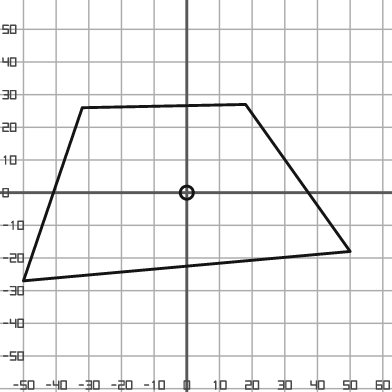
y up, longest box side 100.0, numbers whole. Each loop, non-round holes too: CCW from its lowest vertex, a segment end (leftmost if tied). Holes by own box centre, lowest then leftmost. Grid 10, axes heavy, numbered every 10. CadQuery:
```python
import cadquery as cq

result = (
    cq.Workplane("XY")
    .moveTo(-50.0, -27.0)
    .lineTo(50.0, -18.0)
    .lineTo(18.0, 27.0)
    .lineTo(-32.0, 26.0)
    .close()
    .moveTo(0.0, 0.0)
    .circle(2.0)
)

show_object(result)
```